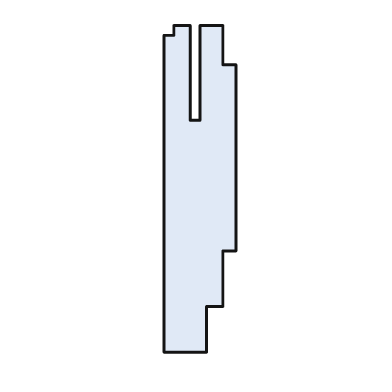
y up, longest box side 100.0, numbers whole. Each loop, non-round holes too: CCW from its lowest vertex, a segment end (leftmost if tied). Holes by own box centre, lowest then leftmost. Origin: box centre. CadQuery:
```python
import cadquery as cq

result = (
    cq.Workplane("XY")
    .moveTo(-11.0, -50.0)
    .lineTo(2.0, -50.0)
    .lineTo(2.0, -36.0)
    .lineTo(7.0, -36.0)
    .lineTo(7.0, -19.0)
    .lineTo(11.0, -19.0)
    .lineTo(11.0, 38.0)
    .lineTo(7.0, 38.0)
    .lineTo(7.0, 50.0)
    .lineTo(0.0, 50.0)
    .lineTo(0.0, 21.0)
    .lineTo(-3.0, 21.0)
    .lineTo(-3.0, 50.0)
    .lineTo(-8.0, 50.0)
    .lineTo(-8.0, 47.0)
    .lineTo(-11.0, 47.0)
    .close()
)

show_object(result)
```